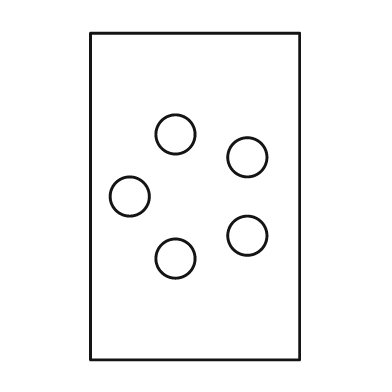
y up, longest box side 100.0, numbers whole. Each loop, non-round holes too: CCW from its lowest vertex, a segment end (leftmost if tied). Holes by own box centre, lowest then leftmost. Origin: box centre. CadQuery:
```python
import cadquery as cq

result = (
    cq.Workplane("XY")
    .moveTo(-32.0, -50.0)
    .lineTo(32.0, -50.0)
    .lineTo(32.0, 50.0)
    .lineTo(-32.0, 50.0)
    .close()
    .moveTo(-6.0, -19.0)
    .circle(6.0)
    .moveTo(16.0, -12.0)
    .circle(6.0)
    .moveTo(-20.0, 0.0)
    .circle(6.0)
    .moveTo(16.0, 12.0)
    .circle(6.0)
    .moveTo(-6.0, 19.0)
    .circle(6.0)
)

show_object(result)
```